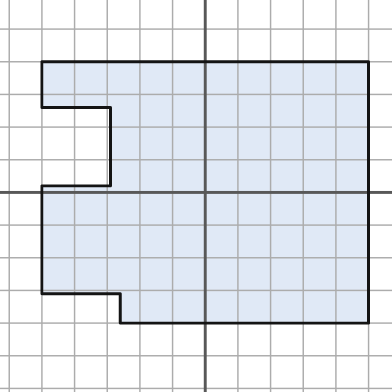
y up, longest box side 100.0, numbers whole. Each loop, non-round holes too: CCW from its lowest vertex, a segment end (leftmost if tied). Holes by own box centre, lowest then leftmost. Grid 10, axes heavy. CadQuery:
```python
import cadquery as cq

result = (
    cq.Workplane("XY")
    .moveTo(-26.0, -40.0)
    .lineTo(50.0, -40.0)
    .lineTo(50.0, 40.0)
    .lineTo(-50.0, 40.0)
    .lineTo(-50.0, 26.0)
    .lineTo(-29.0, 26.0)
    .lineTo(-29.0, 2.0)
    .lineTo(-50.0, 2.0)
    .lineTo(-50.0, -31.0)
    .lineTo(-26.0, -31.0)
    .close()
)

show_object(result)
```